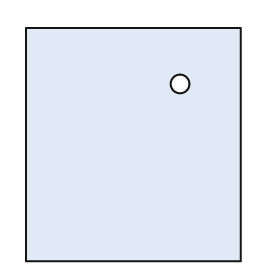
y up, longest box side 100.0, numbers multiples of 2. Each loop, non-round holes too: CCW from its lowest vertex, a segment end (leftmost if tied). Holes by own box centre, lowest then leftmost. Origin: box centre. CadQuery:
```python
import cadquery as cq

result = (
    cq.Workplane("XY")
    .moveTo(-46.0, -50.0)
    .lineTo(46.0, -50.0)
    .lineTo(46.0, 50.0)
    .lineTo(-46.0, 50.0)
    .close()
    .moveTo(20.0, 26.0)
    .circle(4.0)
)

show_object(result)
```